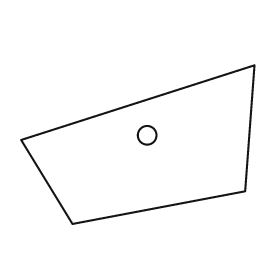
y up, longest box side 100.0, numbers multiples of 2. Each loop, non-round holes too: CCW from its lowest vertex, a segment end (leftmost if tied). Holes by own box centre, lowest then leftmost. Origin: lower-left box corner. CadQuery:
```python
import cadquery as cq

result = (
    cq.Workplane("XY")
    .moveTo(22.0, 0.0)
    .lineTo(96.0, 14.0)
    .lineTo(100.0, 68.0)
    .lineTo(0.0, 36.0)
    .close()
    .moveTo(54.0, 38.0)
    .circle(4.0)
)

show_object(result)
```